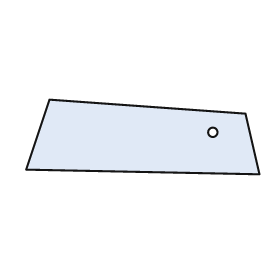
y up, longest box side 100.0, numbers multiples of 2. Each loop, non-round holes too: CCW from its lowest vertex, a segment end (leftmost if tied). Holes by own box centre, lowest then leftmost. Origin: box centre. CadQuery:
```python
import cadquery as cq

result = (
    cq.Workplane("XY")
    .moveTo(50.0, -16.0)
    .lineTo(44.0, 10.0)
    .lineTo(-40.0, 16.0)
    .lineTo(-50.0, -14.0)
    .close()
    .moveTo(30.0, 2.0)
    .circle(2.0)
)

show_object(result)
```